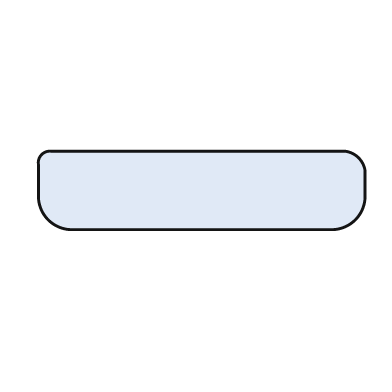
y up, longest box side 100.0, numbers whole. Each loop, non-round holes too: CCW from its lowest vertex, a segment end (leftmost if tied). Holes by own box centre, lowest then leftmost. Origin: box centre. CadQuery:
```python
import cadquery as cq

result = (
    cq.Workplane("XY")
    .moveTo(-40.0, -12.0)
    .lineTo(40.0, -12.0)
    .threePointArc((47.0, -9.0), (50.0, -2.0))
    .lineTo(50.0, 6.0)
    .threePointArc((48.0, 10.0), (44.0, 12.0))
    .lineTo(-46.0, 12.0)
    .threePointArc((-49.0, 11.0), (-50.0, 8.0))
    .lineTo(-50.0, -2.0)
    .threePointArc((-47.0, -9.0), (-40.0, -12.0))
    .close()
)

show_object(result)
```